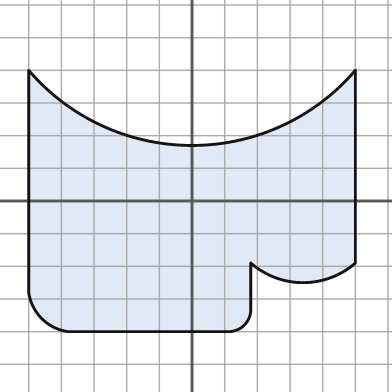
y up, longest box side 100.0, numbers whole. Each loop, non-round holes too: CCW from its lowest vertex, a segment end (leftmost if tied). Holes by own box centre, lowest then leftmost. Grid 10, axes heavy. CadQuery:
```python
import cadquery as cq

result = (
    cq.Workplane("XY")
    .moveTo(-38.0, -40.0)
    .lineTo(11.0, -40.0)
    .threePointArc((16.0, -38.0), (18.0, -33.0))
    .lineTo(18.0, -19.0)
    .threePointArc((34.0, -25.0), (50.0, -19.0))
    .lineTo(50.0, 40.0)
    .threePointArc((0.0, 17.0), (-50.0, 40.0))
    .lineTo(-50.0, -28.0)
    .threePointArc((-46.0, -36.0), (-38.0, -40.0))
    .close()
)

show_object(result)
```